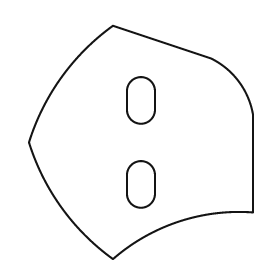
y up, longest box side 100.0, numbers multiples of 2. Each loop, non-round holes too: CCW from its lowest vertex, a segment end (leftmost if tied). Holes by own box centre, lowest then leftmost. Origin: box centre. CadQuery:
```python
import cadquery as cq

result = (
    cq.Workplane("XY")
    .moveTo(-12.0, -50.0)
    .threePointArc((16.0, -34.0), (48.0, -30.0))
    .lineTo(48.0, 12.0)
    .threePointArc((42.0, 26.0), (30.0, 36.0))
    .lineTo(-12.0, 50.0)
    .threePointArc((-34.0, 28.0), (-48.0, 0.0))
    .threePointArc((-34.0, -28.0), (-12.0, -50.0))
    .close()
    .moveTo(-6.0, -22.0)
    .threePointArc((0.0, -28.0), (6.0, -22.0))
    .lineTo(6.0, -14.0)
    .threePointArc((0.0, -8.0), (-6.0, -14.0))
    .close()
    .moveTo(-6.0, 14.0)
    .threePointArc((0.0, 8.0), (6.0, 14.0))
    .lineTo(6.0, 22.0)
    .threePointArc((0.0, 28.0), (-6.0, 22.0))
    .close()
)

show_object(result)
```